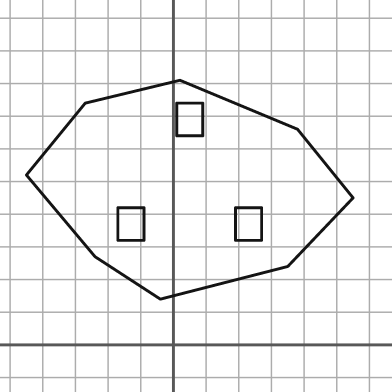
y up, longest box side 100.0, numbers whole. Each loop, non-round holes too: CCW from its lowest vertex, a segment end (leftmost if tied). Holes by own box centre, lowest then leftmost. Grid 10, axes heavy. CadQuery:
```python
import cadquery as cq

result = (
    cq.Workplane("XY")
    .moveTo(-4.0, 14.0)
    .lineTo(35.0, 24.0)
    .lineTo(55.0, 45.0)
    .lineTo(38.0, 66.0)
    .lineTo(2.0, 81.0)
    .lineTo(-27.0, 74.0)
    .lineTo(-45.0, 52.0)
    .lineTo(-24.0, 27.0)
    .close()
    .moveTo(-17.0, 32.0)
    .lineTo(-9.0, 32.0)
    .lineTo(-9.0, 42.0)
    .lineTo(-17.0, 42.0)
    .close()
    .moveTo(19.0, 32.0)
    .lineTo(27.0, 32.0)
    .lineTo(27.0, 42.0)
    .lineTo(19.0, 42.0)
    .close()
    .moveTo(1.0, 64.0)
    .lineTo(9.0, 64.0)
    .lineTo(9.0, 74.0)
    .lineTo(1.0, 74.0)
    .close()
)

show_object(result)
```